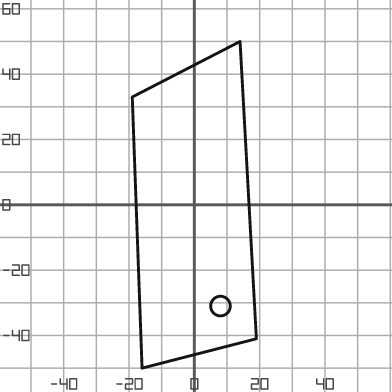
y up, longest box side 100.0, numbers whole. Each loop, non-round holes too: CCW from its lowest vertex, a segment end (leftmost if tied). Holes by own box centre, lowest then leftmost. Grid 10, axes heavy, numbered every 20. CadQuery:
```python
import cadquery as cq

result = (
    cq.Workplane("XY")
    .moveTo(-16.0, -50.0)
    .lineTo(19.0, -41.0)
    .lineTo(14.0, 50.0)
    .lineTo(-19.0, 33.0)
    .close()
    .moveTo(8.0, -31.0)
    .circle(3.0)
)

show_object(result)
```